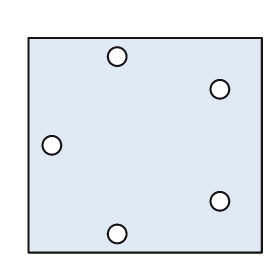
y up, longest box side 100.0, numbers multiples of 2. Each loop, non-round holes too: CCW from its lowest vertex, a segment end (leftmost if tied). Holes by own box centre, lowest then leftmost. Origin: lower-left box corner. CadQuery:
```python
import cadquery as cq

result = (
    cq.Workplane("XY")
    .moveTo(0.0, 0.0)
    .lineTo(100.0, 0.0)
    .lineTo(100.0, 92.0)
    .lineTo(0.0, 92.0)
    .close()
    .moveTo(38.0, 8.0)
    .circle(4.0)
    .moveTo(82.0, 22.0)
    .circle(4.0)
    .moveTo(10.0, 46.0)
    .circle(4.0)
    .moveTo(82.0, 70.0)
    .circle(4.0)
    .moveTo(38.0, 84.0)
    .circle(4.0)
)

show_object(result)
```